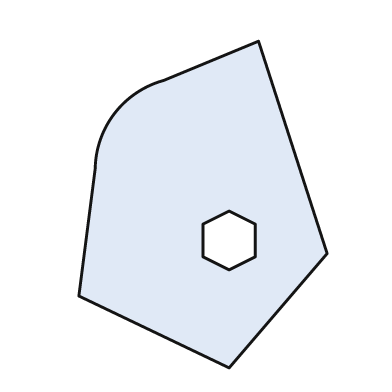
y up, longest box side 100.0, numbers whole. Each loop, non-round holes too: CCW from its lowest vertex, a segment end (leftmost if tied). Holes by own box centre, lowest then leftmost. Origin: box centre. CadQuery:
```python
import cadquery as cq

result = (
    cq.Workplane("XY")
    .moveTo(8.0, -50.0)
    .lineTo(38.0, -15.0)
    .lineTo(17.0, 50.0)
    .lineTo(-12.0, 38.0)
    .threePointArc((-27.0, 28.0), (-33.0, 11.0))
    .lineTo(-38.0, -28.0)
    .close()
    .moveTo(8.0, -20.0)
    .lineTo(16.0, -16.0)
    .lineTo(16.0, -6.0)
    .lineTo(8.0, -2.0)
    .lineTo(0.0, -6.0)
    .lineTo(0.0, -16.0)
    .close()
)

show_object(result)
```